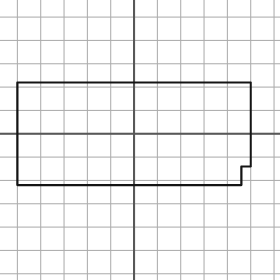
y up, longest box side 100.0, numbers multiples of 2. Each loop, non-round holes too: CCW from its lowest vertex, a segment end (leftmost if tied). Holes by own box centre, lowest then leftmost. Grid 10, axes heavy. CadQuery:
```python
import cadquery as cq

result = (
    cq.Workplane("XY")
    .moveTo(-50.0, -22.0)
    .lineTo(46.0, -22.0)
    .lineTo(46.0, -14.0)
    .lineTo(50.0, -14.0)
    .lineTo(50.0, 22.0)
    .lineTo(-50.0, 22.0)
    .close()
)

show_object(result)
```